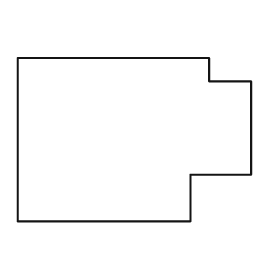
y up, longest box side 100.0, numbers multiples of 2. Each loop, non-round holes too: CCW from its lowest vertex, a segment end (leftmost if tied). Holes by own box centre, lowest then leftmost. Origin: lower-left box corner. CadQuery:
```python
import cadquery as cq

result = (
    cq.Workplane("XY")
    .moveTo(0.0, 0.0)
    .lineTo(74.0, 0.0)
    .lineTo(74.0, 20.0)
    .lineTo(100.0, 20.0)
    .lineTo(100.0, 60.0)
    .lineTo(82.0, 60.0)
    .lineTo(82.0, 70.0)
    .lineTo(0.0, 70.0)
    .close()
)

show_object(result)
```